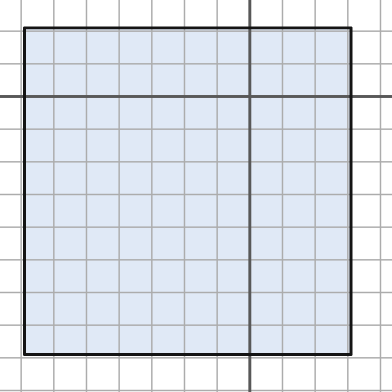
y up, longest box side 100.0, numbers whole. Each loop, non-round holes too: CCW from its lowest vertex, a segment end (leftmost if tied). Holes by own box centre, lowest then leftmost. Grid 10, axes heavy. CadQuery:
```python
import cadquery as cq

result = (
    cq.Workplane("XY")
    .moveTo(-69.0, -79.0)
    .lineTo(31.0, -79.0)
    .lineTo(31.0, 21.0)
    .lineTo(-69.0, 21.0)
    .close()
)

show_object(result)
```